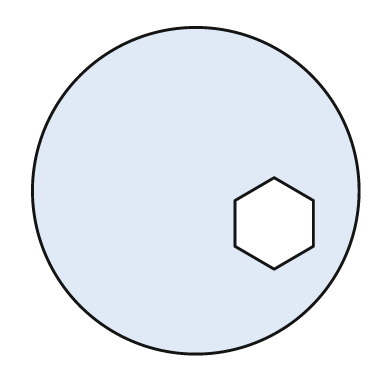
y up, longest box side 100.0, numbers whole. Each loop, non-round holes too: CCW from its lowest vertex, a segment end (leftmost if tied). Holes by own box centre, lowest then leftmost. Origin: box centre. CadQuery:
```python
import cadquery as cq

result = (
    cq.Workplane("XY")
    .moveTo(0.0, 0.0)
    .circle(50.0)
    .moveTo(24.0, -24.0)
    .lineTo(36.0, -17.0)
    .lineTo(36.0, -3.0)
    .lineTo(24.0, 4.0)
    .lineTo(12.0, -3.0)
    .lineTo(12.0, -17.0)
    .close()
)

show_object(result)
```